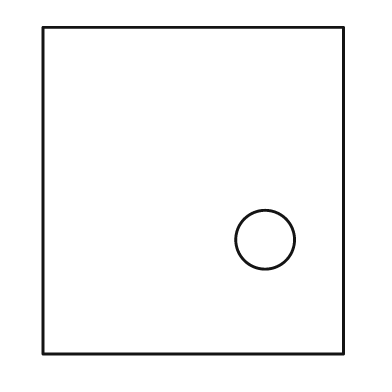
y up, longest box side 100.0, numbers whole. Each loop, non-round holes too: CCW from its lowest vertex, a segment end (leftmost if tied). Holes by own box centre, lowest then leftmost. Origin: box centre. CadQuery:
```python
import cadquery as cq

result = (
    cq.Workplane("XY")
    .moveTo(-46.0, -50.0)
    .lineTo(46.0, -50.0)
    .lineTo(46.0, 50.0)
    .lineTo(-46.0, 50.0)
    .close()
    .moveTo(22.0, -15.0)
    .circle(9.0)
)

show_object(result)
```